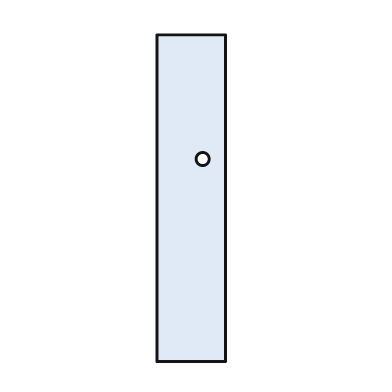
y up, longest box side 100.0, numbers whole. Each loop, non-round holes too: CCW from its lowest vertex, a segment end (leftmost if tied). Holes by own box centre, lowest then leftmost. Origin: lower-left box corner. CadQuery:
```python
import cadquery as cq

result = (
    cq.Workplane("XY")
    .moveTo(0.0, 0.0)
    .lineTo(21.0, 0.0)
    .lineTo(21.0, 100.0)
    .lineTo(0.0, 100.0)
    .close()
    .moveTo(14.0, 62.0)
    .circle(2.0)
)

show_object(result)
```